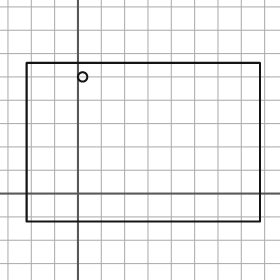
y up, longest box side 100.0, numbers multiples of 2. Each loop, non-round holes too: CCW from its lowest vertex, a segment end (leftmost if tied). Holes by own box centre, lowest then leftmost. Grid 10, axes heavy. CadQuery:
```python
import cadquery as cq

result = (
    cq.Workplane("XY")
    .moveTo(-22.0, -12.0)
    .lineTo(78.0, -12.0)
    .lineTo(78.0, 56.0)
    .lineTo(-22.0, 56.0)
    .close()
    .moveTo(2.0, 50.0)
    .circle(2.0)
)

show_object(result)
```